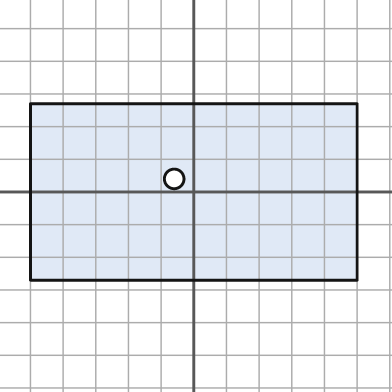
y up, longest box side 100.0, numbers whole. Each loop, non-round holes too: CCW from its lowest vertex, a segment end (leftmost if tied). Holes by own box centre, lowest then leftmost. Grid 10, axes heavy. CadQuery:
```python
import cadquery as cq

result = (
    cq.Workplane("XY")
    .moveTo(-50.0, -27.0)
    .lineTo(50.0, -27.0)
    .lineTo(50.0, 27.0)
    .lineTo(-50.0, 27.0)
    .close()
    .moveTo(-6.0, 4.0)
    .circle(3.0)
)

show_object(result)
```